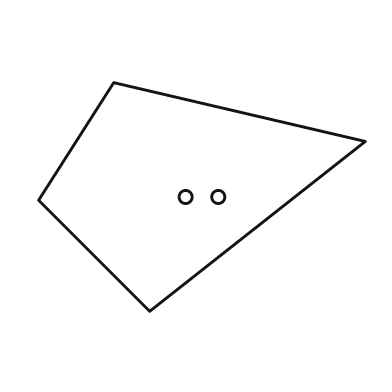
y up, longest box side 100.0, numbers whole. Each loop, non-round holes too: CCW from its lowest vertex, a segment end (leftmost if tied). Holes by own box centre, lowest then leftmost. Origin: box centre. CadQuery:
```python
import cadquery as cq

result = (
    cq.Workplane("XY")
    .moveTo(-16.0, -35.0)
    .lineTo(50.0, 17.0)
    .lineTo(-27.0, 35.0)
    .lineTo(-50.0, -1.0)
    .close()
    .moveTo(-5.0, 0.0)
    .circle(2.0)
    .moveTo(5.0, 0.0)
    .circle(2.0)
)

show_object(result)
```